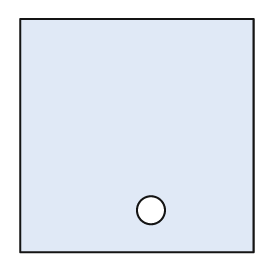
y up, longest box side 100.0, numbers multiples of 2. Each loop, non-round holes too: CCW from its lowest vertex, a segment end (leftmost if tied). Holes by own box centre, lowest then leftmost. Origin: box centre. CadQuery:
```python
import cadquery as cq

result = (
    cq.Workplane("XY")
    .moveTo(-50.0, -50.0)
    .lineTo(50.0, -50.0)
    .lineTo(50.0, 50.0)
    .lineTo(-50.0, 50.0)
    .close()
    .moveTo(6.0, -32.0)
    .circle(6.0)
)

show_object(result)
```